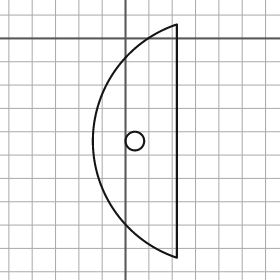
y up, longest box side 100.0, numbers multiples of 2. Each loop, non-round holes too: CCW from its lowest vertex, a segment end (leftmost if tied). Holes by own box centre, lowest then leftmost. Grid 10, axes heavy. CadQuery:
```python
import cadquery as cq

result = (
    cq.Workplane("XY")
    .moveTo(22.0, -94.0)
    .lineTo(22.0, 6.0)
    .threePointArc((-14.0, -44.0), (22.0, -94.0))
    .close()
    .moveTo(4.0, -44.0)
    .circle(4.0)
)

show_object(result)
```